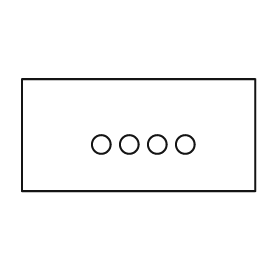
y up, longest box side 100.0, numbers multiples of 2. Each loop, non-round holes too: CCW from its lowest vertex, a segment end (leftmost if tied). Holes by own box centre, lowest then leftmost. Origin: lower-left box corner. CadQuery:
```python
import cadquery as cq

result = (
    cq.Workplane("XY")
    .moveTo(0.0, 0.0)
    .lineTo(100.0, 0.0)
    .lineTo(100.0, 48.0)
    .lineTo(0.0, 48.0)
    .close()
    .moveTo(34.0, 20.0)
    .circle(4.0)
    .moveTo(46.0, 20.0)
    .circle(4.0)
    .moveTo(58.0, 20.0)
    .circle(4.0)
    .moveTo(70.0, 20.0)
    .circle(4.0)
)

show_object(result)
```